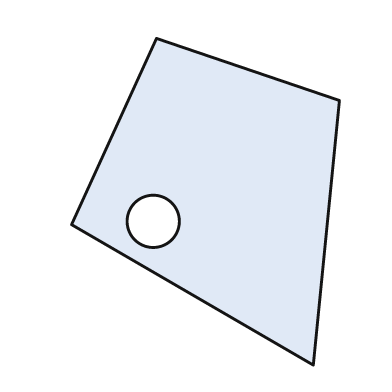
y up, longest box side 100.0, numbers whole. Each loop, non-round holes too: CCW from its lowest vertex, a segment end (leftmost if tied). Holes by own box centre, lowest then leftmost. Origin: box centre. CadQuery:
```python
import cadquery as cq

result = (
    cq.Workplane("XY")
    .moveTo(33.0, -50.0)
    .lineTo(41.0, 31.0)
    .lineTo(-15.0, 50.0)
    .lineTo(-41.0, -7.0)
    .close()
    .moveTo(-16.0, -6.0)
    .circle(8.0)
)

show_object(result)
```